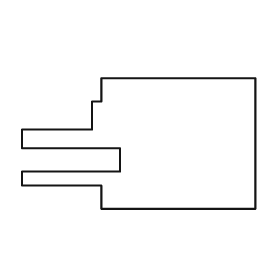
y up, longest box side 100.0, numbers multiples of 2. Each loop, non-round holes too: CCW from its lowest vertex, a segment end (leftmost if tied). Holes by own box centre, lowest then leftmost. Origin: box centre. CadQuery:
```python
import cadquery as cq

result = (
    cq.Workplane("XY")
    .moveTo(-16.0, -28.0)
    .lineTo(50.0, -28.0)
    .lineTo(50.0, 28.0)
    .lineTo(-16.0, 28.0)
    .lineTo(-16.0, 18.0)
    .lineTo(-20.0, 18.0)
    .lineTo(-20.0, 6.0)
    .lineTo(-50.0, 6.0)
    .lineTo(-50.0, -2.0)
    .lineTo(-8.0, -2.0)
    .lineTo(-8.0, -12.0)
    .lineTo(-50.0, -12.0)
    .lineTo(-50.0, -18.0)
    .lineTo(-16.0, -18.0)
    .close()
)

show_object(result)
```